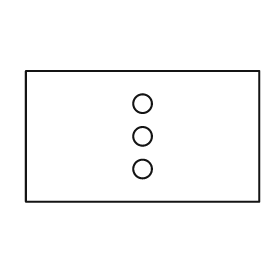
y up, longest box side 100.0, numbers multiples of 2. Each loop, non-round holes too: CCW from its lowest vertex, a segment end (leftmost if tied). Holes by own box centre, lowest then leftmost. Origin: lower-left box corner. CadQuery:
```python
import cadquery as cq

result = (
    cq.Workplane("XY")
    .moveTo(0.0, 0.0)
    .lineTo(100.0, 0.0)
    .lineTo(100.0, 56.0)
    .lineTo(0.0, 56.0)
    .close()
    .moveTo(50.0, 14.0)
    .circle(4.0)
    .moveTo(50.0, 28.0)
    .circle(4.0)
    .moveTo(50.0, 42.0)
    .circle(4.0)
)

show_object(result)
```